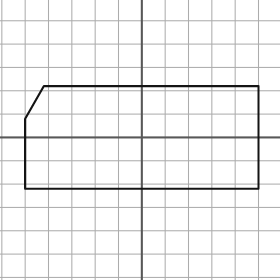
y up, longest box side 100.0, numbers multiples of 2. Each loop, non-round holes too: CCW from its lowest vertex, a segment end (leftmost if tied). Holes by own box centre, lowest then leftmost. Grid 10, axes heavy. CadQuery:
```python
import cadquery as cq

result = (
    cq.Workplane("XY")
    .moveTo(-50.0, -22.0)
    .lineTo(50.0, -22.0)
    .lineTo(50.0, 22.0)
    .lineTo(-42.0, 22.0)
    .lineTo(-50.0, 8.0)
    .close()
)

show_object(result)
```